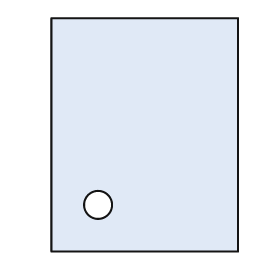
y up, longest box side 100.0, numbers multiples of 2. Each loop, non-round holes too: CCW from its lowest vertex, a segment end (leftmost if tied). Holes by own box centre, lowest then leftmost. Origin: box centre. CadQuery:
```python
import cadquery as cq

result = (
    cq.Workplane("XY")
    .moveTo(-40.0, -50.0)
    .lineTo(40.0, -50.0)
    .lineTo(40.0, 50.0)
    .lineTo(-40.0, 50.0)
    .close()
    .moveTo(-20.0, -30.0)
    .circle(6.0)
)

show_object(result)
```